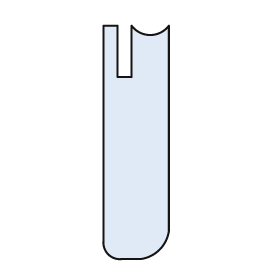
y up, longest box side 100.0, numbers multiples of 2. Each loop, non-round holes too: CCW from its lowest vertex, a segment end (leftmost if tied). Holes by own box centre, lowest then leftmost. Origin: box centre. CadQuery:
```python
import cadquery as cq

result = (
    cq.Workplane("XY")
    .moveTo(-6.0, -50.0)
    .lineTo(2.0, -50.0)
    .threePointArc((10.0, -46.0), (14.0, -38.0))
    .lineTo(14.0, 50.0)
    .threePointArc((6.0, 46.0), (-2.0, 50.0))
    .lineTo(-2.0, 28.0)
    .lineTo(-8.0, 28.0)
    .lineTo(-8.0, 50.0)
    .lineTo(-14.0, 50.0)
    .lineTo(-14.0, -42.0)
    .threePointArc((-12.0, -48.0), (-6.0, -50.0))
    .close()
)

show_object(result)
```